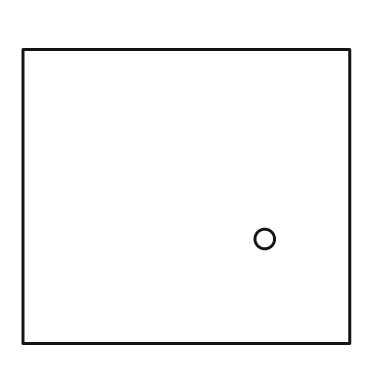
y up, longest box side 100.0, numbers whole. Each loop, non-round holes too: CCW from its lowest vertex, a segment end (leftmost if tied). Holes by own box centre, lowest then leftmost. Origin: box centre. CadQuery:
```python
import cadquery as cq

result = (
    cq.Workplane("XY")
    .moveTo(-50.0, -45.0)
    .lineTo(50.0, -45.0)
    .lineTo(50.0, 45.0)
    .lineTo(-50.0, 45.0)
    .close()
    .moveTo(24.0, -13.0)
    .circle(3.0)
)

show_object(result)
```